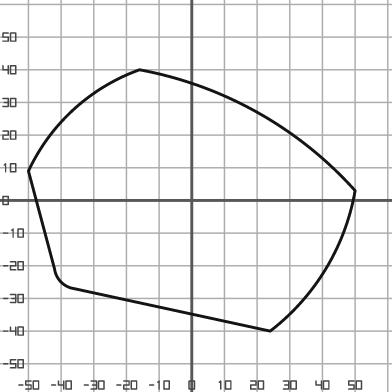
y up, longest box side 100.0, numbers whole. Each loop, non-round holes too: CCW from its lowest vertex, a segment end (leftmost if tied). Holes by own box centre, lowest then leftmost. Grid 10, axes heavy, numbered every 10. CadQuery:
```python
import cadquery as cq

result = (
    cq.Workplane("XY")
    .moveTo(24.0, -40.0)
    .threePointArc((41.0, -21.0), (50.0, 3.0))
    .threePointArc((20.0, 27.0), (-16.0, 40.0))
    .threePointArc((-36.0, 28.0), (-50.0, 9.0))
    .lineTo(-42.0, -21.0)
    .threePointArc((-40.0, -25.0), (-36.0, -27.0))
    .close()
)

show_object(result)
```